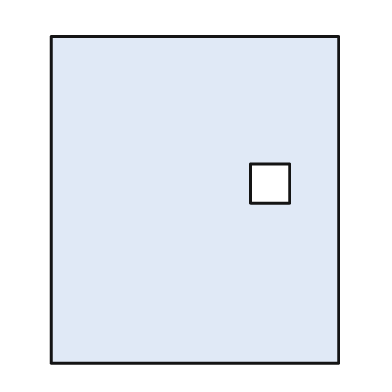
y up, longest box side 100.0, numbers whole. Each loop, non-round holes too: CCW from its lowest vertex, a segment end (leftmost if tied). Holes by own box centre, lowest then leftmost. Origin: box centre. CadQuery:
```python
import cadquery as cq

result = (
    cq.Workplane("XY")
    .moveTo(-44.0, -50.0)
    .lineTo(44.0, -50.0)
    .lineTo(44.0, 50.0)
    .lineTo(-44.0, 50.0)
    .close()
    .moveTo(17.0, -1.0)
    .lineTo(29.0, -1.0)
    .lineTo(29.0, 11.0)
    .lineTo(17.0, 11.0)
    .close()
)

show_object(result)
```